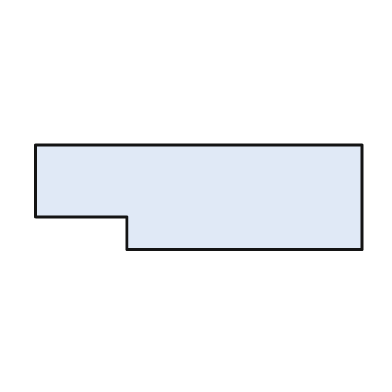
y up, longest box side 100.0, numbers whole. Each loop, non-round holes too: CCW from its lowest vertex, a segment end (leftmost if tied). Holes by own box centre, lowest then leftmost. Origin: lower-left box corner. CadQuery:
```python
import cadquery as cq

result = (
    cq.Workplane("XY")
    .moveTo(28.0, 0.0)
    .lineTo(100.0, 0.0)
    .lineTo(100.0, 32.0)
    .lineTo(0.0, 32.0)
    .lineTo(0.0, 10.0)
    .lineTo(28.0, 10.0)
    .close()
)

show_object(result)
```